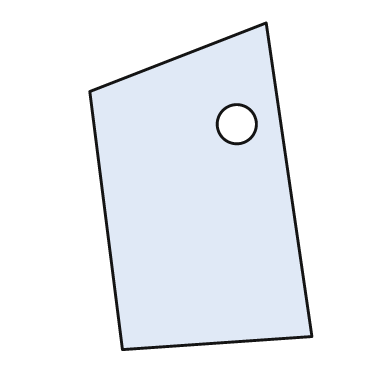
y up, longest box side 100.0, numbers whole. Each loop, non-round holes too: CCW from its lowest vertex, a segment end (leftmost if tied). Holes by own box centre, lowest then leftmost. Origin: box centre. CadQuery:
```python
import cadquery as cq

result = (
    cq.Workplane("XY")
    .moveTo(-24.0, -50.0)
    .lineTo(34.0, -46.0)
    .lineTo(20.0, 50.0)
    .lineTo(-34.0, 29.0)
    .close()
    .moveTo(11.0, 19.0)
    .circle(6.0)
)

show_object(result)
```